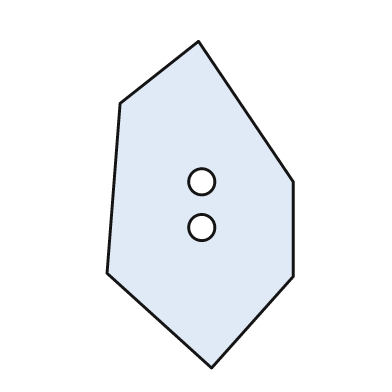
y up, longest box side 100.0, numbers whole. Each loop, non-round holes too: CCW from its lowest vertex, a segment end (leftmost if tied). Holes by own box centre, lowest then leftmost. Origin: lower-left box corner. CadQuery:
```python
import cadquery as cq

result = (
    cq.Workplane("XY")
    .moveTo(32.0, 0.0)
    .lineTo(57.0, 28.0)
    .lineTo(57.0, 57.0)
    .lineTo(28.0, 100.0)
    .lineTo(4.0, 81.0)
    .lineTo(0.0, 29.0)
    .close()
    .moveTo(29.0, 43.0)
    .circle(4.0)
    .moveTo(29.0, 57.0)
    .circle(4.0)
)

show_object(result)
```